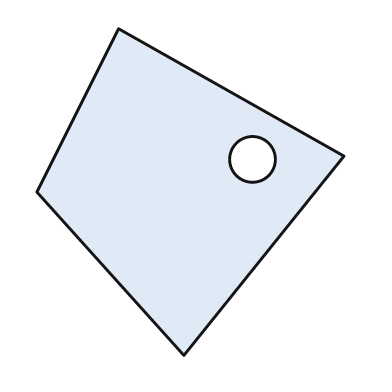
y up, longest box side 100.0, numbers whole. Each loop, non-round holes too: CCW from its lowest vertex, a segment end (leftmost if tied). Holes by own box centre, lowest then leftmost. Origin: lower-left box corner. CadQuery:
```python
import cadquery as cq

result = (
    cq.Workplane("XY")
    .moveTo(45.0, 0.0)
    .lineTo(94.0, 61.0)
    .lineTo(25.0, 100.0)
    .lineTo(0.0, 50.0)
    .close()
    .moveTo(66.0, 60.0)
    .circle(7.0)
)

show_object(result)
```